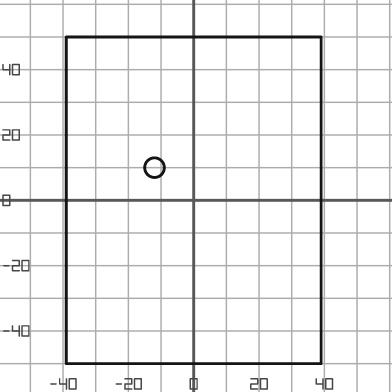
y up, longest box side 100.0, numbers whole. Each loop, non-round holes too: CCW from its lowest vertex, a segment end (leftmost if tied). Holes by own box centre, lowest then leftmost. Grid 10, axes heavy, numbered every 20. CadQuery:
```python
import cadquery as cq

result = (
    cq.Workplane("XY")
    .moveTo(-39.0, -50.0)
    .lineTo(39.0, -50.0)
    .lineTo(39.0, 50.0)
    .lineTo(-39.0, 50.0)
    .close()
    .moveTo(-12.0, 10.0)
    .circle(3.0)
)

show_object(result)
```